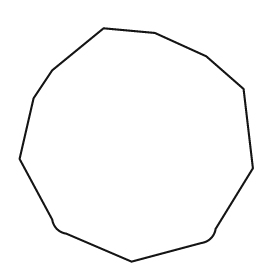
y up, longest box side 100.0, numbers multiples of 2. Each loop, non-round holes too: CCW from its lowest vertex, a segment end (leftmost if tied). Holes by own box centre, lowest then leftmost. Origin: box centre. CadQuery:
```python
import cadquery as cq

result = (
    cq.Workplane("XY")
    .moveTo(-2.0, -50.0)
    .lineTo(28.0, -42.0)
    .threePointArc((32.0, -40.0), (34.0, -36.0))
    .lineTo(50.0, -10.0)
    .lineTo(46.0, 24.0)
    .lineTo(30.0, 38.0)
    .lineTo(8.0, 48.0)
    .lineTo(-14.0, 50.0)
    .lineTo(-36.0, 32.0)
    .lineTo(-44.0, 20.0)
    .lineTo(-50.0, -6.0)
    .lineTo(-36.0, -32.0)
    .threePointArc((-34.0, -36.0), (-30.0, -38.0))
    .close()
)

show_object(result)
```